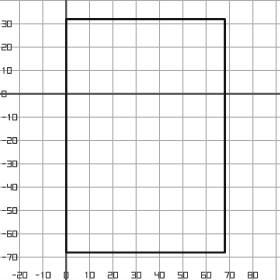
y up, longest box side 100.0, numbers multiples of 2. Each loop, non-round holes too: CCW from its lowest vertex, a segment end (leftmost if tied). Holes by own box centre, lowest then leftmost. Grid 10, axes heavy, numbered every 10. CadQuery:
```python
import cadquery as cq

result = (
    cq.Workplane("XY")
    .moveTo(0.0, -68.0)
    .lineTo(68.0, -68.0)
    .lineTo(68.0, 32.0)
    .lineTo(0.0, 32.0)
    .close()
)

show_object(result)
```